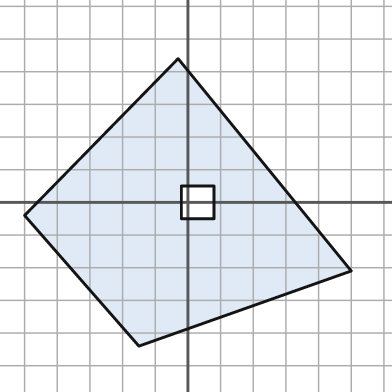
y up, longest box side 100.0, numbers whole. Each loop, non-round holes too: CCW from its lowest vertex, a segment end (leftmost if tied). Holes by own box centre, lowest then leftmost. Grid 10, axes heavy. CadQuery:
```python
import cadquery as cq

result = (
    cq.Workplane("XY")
    .moveTo(-15.0, -44.0)
    .lineTo(50.0, -21.0)
    .lineTo(-3.0, 44.0)
    .lineTo(-50.0, -4.0)
    .close()
    .moveTo(-2.0, -5.0)
    .lineTo(8.0, -5.0)
    .lineTo(8.0, 5.0)
    .lineTo(-2.0, 5.0)
    .close()
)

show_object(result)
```